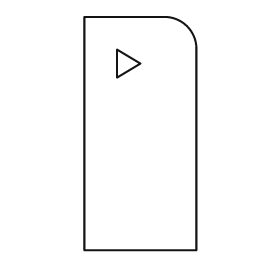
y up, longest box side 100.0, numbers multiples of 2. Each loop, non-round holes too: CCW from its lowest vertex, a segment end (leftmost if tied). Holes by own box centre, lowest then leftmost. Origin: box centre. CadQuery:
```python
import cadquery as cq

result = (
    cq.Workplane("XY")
    .moveTo(-24.0, -50.0)
    .lineTo(24.0, -50.0)
    .lineTo(24.0, 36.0)
    .threePointArc((20.0, 46.0), (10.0, 50.0))
    .lineTo(-24.0, 50.0)
    .close()
    .moveTo(-10.0, 24.0)
    .lineTo(0.0, 30.0)
    .lineTo(-10.0, 36.0)
    .close()
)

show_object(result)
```